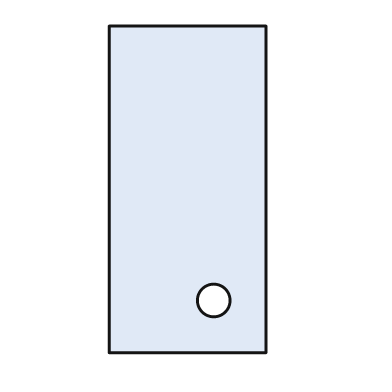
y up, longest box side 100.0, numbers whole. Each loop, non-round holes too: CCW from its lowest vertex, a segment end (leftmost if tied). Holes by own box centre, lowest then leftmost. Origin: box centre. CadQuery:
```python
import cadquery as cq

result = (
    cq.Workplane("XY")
    .moveTo(-24.0, -50.0)
    .lineTo(24.0, -50.0)
    .lineTo(24.0, 50.0)
    .lineTo(-24.0, 50.0)
    .close()
    .moveTo(8.0, -34.0)
    .circle(5.0)
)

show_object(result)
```